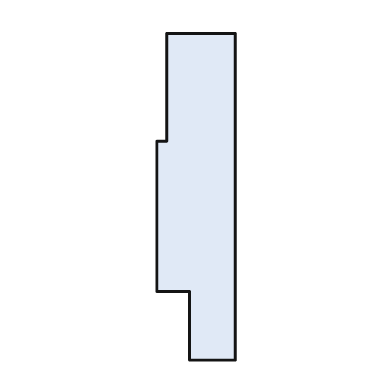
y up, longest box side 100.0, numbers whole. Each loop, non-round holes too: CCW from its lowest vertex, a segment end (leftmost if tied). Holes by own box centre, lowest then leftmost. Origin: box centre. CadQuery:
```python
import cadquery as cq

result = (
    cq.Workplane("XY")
    .moveTo(-2.0, -50.0)
    .lineTo(12.0, -50.0)
    .lineTo(12.0, 50.0)
    .lineTo(-9.0, 50.0)
    .lineTo(-9.0, 17.0)
    .lineTo(-12.0, 17.0)
    .lineTo(-12.0, -29.0)
    .lineTo(-2.0, -29.0)
    .close()
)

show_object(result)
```